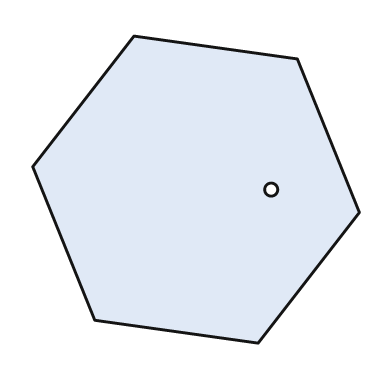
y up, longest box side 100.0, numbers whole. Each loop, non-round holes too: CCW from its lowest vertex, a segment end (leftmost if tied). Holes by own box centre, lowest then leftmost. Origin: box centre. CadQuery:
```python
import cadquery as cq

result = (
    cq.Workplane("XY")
    .moveTo(19.0, -47.0)
    .lineTo(50.0, -7.0)
    .lineTo(31.0, 40.0)
    .lineTo(-19.0, 47.0)
    .lineTo(-50.0, 7.0)
    .lineTo(-31.0, -40.0)
    .close()
    .moveTo(23.0, 0.0)
    .circle(2.0)
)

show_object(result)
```